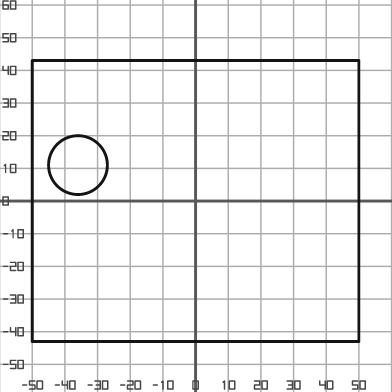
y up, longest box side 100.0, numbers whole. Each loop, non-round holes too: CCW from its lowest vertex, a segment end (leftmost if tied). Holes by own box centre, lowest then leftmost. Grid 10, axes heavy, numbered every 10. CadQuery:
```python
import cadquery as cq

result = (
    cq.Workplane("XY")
    .moveTo(-50.0, -43.0)
    .lineTo(50.0, -43.0)
    .lineTo(50.0, 43.0)
    .lineTo(-50.0, 43.0)
    .close()
    .moveTo(-36.0, 11.0)
    .circle(9.0)
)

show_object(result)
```